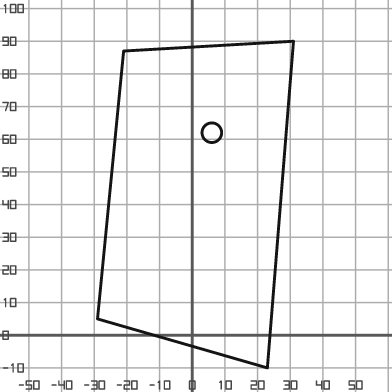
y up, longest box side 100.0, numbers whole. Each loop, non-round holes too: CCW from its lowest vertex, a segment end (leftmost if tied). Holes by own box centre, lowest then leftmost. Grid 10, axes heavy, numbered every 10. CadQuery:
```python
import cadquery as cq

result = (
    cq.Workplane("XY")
    .moveTo(23.0, -10.0)
    .lineTo(31.0, 90.0)
    .lineTo(-21.0, 87.0)
    .lineTo(-29.0, 5.0)
    .close()
    .moveTo(6.0, 62.0)
    .circle(3.0)
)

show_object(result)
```